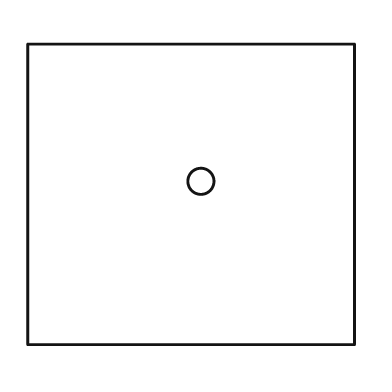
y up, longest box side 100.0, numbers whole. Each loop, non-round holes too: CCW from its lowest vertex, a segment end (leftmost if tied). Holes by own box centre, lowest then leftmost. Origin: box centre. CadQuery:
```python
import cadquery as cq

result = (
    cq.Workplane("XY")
    .moveTo(-50.0, -46.0)
    .lineTo(50.0, -46.0)
    .lineTo(50.0, 46.0)
    .lineTo(-50.0, 46.0)
    .close()
    .moveTo(3.0, 4.0)
    .circle(4.0)
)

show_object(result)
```